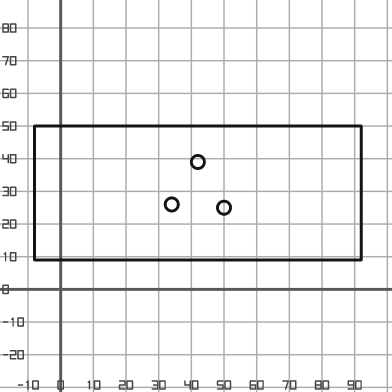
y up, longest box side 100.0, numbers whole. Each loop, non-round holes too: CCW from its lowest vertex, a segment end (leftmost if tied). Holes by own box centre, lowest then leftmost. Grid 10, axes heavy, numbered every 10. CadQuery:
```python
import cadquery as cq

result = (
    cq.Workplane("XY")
    .moveTo(-8.0, 9.0)
    .lineTo(92.0, 9.0)
    .lineTo(92.0, 50.0)
    .lineTo(-8.0, 50.0)
    .close()
    .moveTo(50.0, 25.0)
    .circle(2.0)
    .moveTo(34.0, 26.0)
    .circle(2.0)
    .moveTo(42.0, 39.0)
    .circle(2.0)
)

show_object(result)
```